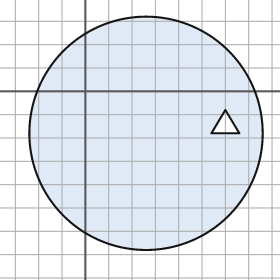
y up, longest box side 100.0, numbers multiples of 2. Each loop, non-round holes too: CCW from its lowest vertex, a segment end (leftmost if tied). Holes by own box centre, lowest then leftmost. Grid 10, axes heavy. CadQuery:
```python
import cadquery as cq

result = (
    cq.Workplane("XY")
    .moveTo(26.0, -18.0)
    .circle(50.0)
    .moveTo(54.0, -18.0)
    .lineTo(66.0, -18.0)
    .lineTo(60.0, -8.0)
    .close()
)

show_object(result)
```